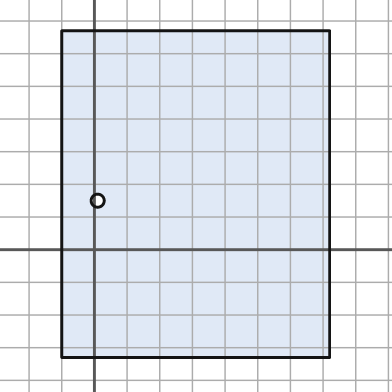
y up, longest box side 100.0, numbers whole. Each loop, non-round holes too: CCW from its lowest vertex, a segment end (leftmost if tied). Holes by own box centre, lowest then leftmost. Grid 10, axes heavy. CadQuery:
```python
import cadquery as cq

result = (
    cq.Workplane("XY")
    .moveTo(-10.0, -33.0)
    .lineTo(72.0, -33.0)
    .lineTo(72.0, 67.0)
    .lineTo(-10.0, 67.0)
    .close()
    .moveTo(1.0, 15.0)
    .circle(2.0)
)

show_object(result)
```